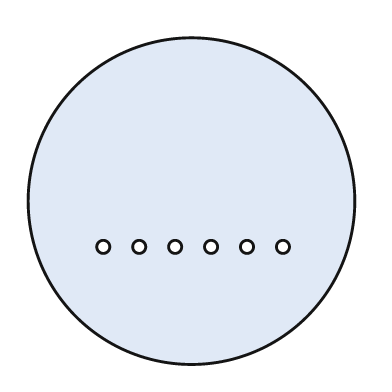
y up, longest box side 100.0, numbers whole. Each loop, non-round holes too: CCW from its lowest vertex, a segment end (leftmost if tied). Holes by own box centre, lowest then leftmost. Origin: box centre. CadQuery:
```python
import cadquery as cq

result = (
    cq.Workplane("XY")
    .moveTo(0.0, 0.0)
    .circle(50.0)
    .moveTo(-27.0, -14.0)
    .circle(2.0)
    .moveTo(-16.0, -14.0)
    .circle(2.0)
    .moveTo(-5.0, -14.0)
    .circle(2.0)
    .moveTo(6.0, -14.0)
    .circle(2.0)
    .moveTo(17.0, -14.0)
    .circle(2.0)
    .moveTo(28.0, -14.0)
    .circle(2.0)
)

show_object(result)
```